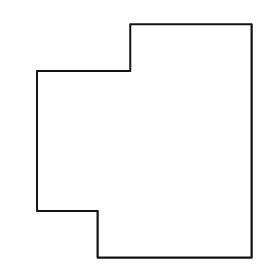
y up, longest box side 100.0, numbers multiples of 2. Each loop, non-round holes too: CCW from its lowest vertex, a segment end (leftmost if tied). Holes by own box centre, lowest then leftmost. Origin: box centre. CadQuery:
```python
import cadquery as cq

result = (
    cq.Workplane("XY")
    .moveTo(-20.0, -50.0)
    .lineTo(46.0, -50.0)
    .lineTo(46.0, 50.0)
    .lineTo(-6.0, 50.0)
    .lineTo(-6.0, 30.0)
    .lineTo(-46.0, 30.0)
    .lineTo(-46.0, -30.0)
    .lineTo(-20.0, -30.0)
    .close()
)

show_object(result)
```